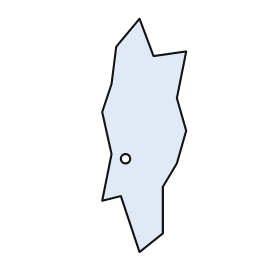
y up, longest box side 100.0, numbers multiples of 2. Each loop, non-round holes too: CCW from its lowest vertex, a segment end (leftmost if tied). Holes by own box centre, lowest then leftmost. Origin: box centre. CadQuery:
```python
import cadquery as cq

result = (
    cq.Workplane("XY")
    .moveTo(-2.0, -50.0)
    .lineTo(8.0, -42.0)
    .lineTo(8.0, -22.0)
    .lineTo(14.0, -12.0)
    .lineTo(18.0, 2.0)
    .lineTo(14.0, 16.0)
    .lineTo(18.0, 36.0)
    .lineTo(4.0, 34.0)
    .lineTo(-2.0, 50.0)
    .lineTo(-12.0, 38.0)
    .lineTo(-14.0, 22.0)
    .lineTo(-18.0, 10.0)
    .lineTo(-14.0, -8.0)
    .lineTo(-18.0, -28.0)
    .lineTo(-10.0, -26.0)
    .close()
    .moveTo(-8.0, -10.0)
    .circle(2.0)
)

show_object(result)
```